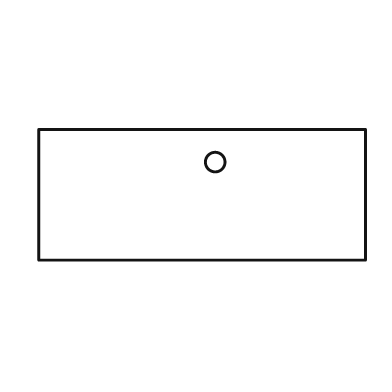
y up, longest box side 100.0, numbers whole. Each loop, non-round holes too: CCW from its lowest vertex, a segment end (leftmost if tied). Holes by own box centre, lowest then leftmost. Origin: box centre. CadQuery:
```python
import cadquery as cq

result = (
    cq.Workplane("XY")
    .moveTo(-50.0, -20.0)
    .lineTo(50.0, -20.0)
    .lineTo(50.0, 20.0)
    .lineTo(-50.0, 20.0)
    .close()
    .moveTo(4.0, 10.0)
    .circle(3.0)
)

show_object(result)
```